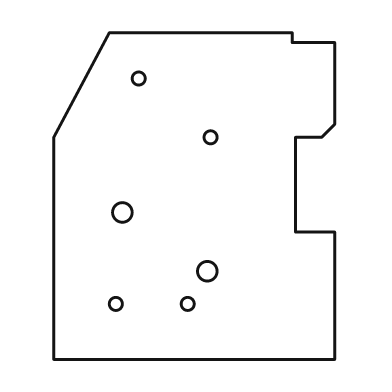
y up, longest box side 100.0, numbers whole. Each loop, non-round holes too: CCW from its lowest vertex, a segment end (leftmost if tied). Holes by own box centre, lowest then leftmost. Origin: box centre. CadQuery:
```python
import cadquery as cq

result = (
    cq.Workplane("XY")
    .moveTo(-43.0, -50.0)
    .lineTo(43.0, -50.0)
    .lineTo(43.0, -11.0)
    .lineTo(31.0, -11.0)
    .lineTo(31.0, 18.0)
    .lineTo(39.0, 18.0)
    .lineTo(43.0, 22.0)
    .lineTo(43.0, 47.0)
    .lineTo(30.0, 47.0)
    .lineTo(30.0, 50.0)
    .lineTo(-26.0, 50.0)
    .lineTo(-43.0, 18.0)
    .close()
    .moveTo(-24.0, -33.0)
    .circle(2.0)
    .moveTo(-2.0, -33.0)
    .circle(2.0)
    .moveTo(4.0, -23.0)
    .circle(3.0)
    .moveTo(-22.0, -5.0)
    .circle(3.0)
    .moveTo(5.0, 18.0)
    .circle(2.0)
    .moveTo(-17.0, 36.0)
    .circle(2.0)
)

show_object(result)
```